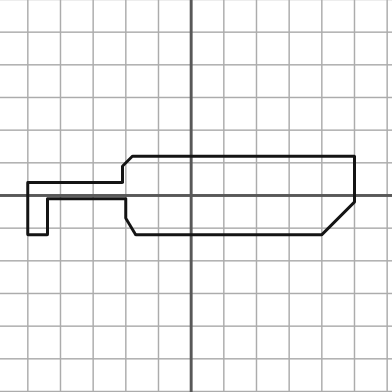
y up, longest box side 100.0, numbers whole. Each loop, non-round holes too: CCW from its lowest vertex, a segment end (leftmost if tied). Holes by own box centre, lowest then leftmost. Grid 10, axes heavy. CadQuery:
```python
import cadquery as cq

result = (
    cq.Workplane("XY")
    .moveTo(-50.0, -12.0)
    .lineTo(-44.0, -12.0)
    .lineTo(-44.0, -1.0)
    .lineTo(-20.0, -1.0)
    .lineTo(-20.0, -7.0)
    .lineTo(-17.0, -12.0)
    .lineTo(40.0, -12.0)
    .lineTo(50.0, -2.0)
    .lineTo(50.0, 12.0)
    .lineTo(-18.0, 12.0)
    .lineTo(-21.0, 9.0)
    .lineTo(-21.0, 4.0)
    .lineTo(-50.0, 4.0)
    .close()
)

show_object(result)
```